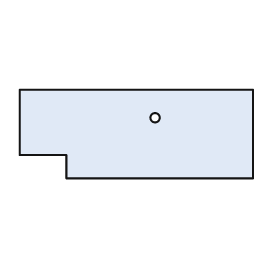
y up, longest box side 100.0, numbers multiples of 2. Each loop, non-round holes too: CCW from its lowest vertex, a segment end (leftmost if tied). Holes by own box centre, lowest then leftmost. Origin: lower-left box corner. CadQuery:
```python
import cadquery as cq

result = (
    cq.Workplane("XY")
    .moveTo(20.0, 0.0)
    .lineTo(100.0, 0.0)
    .lineTo(100.0, 38.0)
    .lineTo(0.0, 38.0)
    .lineTo(0.0, 10.0)
    .lineTo(20.0, 10.0)
    .close()
    .moveTo(58.0, 26.0)
    .circle(2.0)
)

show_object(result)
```